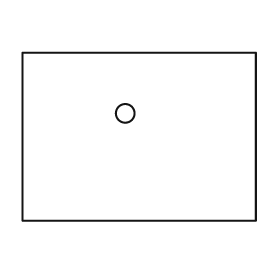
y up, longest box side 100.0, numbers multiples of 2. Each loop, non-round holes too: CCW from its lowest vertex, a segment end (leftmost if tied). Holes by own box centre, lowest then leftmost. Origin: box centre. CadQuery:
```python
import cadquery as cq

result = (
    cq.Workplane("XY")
    .moveTo(-50.0, -36.0)
    .lineTo(50.0, -36.0)
    .lineTo(50.0, 36.0)
    .lineTo(-50.0, 36.0)
    .close()
    .moveTo(-6.0, 10.0)
    .circle(4.0)
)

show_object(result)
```